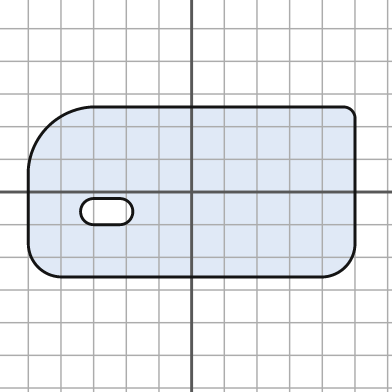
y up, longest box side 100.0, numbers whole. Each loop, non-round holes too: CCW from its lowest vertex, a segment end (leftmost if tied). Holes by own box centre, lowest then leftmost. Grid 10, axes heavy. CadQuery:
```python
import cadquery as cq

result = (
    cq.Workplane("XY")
    .moveTo(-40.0, -26.0)
    .lineTo(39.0, -26.0)
    .threePointArc((47.0, -23.0), (50.0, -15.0))
    .lineTo(50.0, 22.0)
    .threePointArc((49.0, 25.0), (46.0, 26.0))
    .lineTo(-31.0, 26.0)
    .threePointArc((-44.0, 20.0), (-50.0, 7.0))
    .lineTo(-50.0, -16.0)
    .threePointArc((-47.0, -23.0), (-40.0, -26.0))
    .close()
    .moveTo(-30.0, -10.0)
    .lineTo(-22.0, -10.0)
    .threePointArc((-18.0, -6.0), (-22.0, -2.0))
    .lineTo(-30.0, -2.0)
    .threePointArc((-34.0, -6.0), (-30.0, -10.0))
    .close()
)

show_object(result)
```